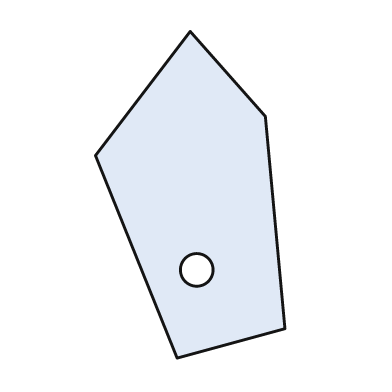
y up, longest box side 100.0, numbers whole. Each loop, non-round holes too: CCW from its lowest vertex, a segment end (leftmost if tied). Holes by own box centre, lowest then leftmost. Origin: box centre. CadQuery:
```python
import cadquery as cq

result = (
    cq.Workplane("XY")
    .moveTo(-4.0, -50.0)
    .lineTo(29.0, -41.0)
    .lineTo(23.0, 24.0)
    .lineTo(0.0, 50.0)
    .lineTo(-29.0, 12.0)
    .close()
    .moveTo(2.0, -23.0)
    .circle(5.0)
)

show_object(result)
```